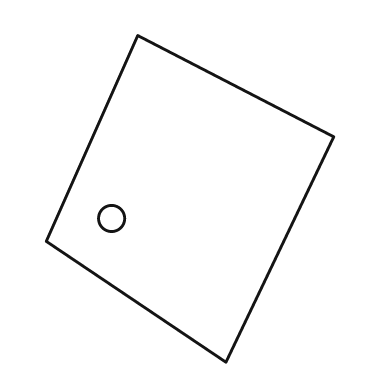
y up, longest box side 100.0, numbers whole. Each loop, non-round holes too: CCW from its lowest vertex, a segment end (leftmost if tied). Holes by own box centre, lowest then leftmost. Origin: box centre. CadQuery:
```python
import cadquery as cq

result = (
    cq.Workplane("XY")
    .moveTo(11.0, -50.0)
    .lineTo(44.0, 19.0)
    .lineTo(-16.0, 50.0)
    .lineTo(-44.0, -13.0)
    .close()
    .moveTo(-24.0, -6.0)
    .circle(4.0)
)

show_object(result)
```